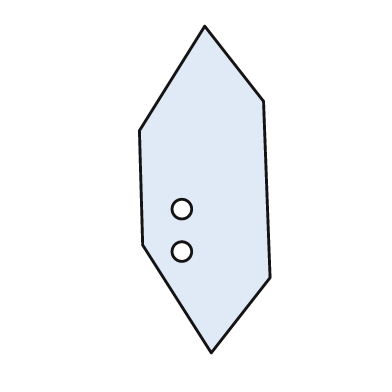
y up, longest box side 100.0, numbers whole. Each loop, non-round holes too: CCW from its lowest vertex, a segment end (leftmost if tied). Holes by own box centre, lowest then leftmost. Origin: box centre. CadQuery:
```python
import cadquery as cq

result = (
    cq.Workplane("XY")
    .moveTo(2.0, -50.0)
    .lineTo(20.0, -27.0)
    .lineTo(18.0, 27.0)
    .lineTo(0.0, 50.0)
    .lineTo(-20.0, 18.0)
    .lineTo(-19.0, -17.0)
    .close()
    .moveTo(-7.0, -19.0)
    .circle(3.0)
    .moveTo(-7.0, -6.0)
    .circle(3.0)
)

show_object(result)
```